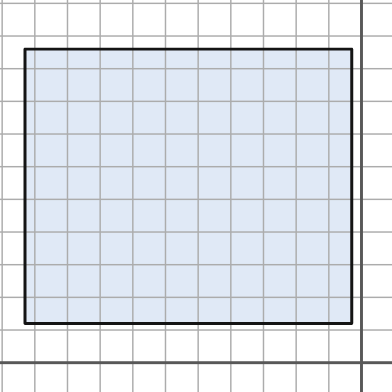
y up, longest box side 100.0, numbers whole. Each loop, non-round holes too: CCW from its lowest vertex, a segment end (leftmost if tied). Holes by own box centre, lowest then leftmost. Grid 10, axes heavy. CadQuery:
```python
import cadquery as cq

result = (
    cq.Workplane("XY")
    .moveTo(-103.0, 12.0)
    .lineTo(-3.0, 12.0)
    .lineTo(-3.0, 96.0)
    .lineTo(-103.0, 96.0)
    .close()
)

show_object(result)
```